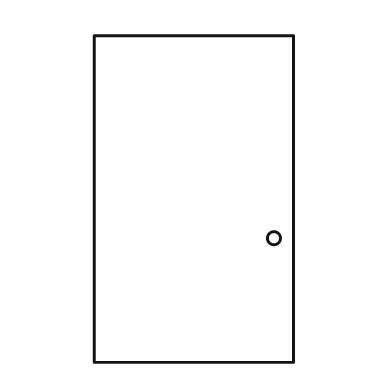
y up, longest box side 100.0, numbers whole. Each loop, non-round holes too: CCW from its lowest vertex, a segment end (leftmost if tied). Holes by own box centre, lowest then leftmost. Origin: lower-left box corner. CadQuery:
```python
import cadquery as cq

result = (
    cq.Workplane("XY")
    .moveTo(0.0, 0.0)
    .lineTo(61.0, 0.0)
    .lineTo(61.0, 100.0)
    .lineTo(0.0, 100.0)
    .close()
    .moveTo(55.0, 38.0)
    .circle(2.0)
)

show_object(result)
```